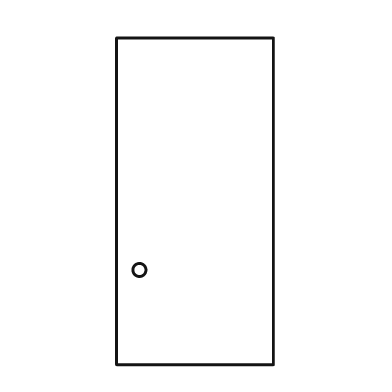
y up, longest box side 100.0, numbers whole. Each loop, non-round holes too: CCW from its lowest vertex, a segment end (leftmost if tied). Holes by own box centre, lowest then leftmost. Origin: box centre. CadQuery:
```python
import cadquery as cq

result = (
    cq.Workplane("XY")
    .moveTo(-24.0, -50.0)
    .lineTo(24.0, -50.0)
    .lineTo(24.0, 50.0)
    .lineTo(-24.0, 50.0)
    .close()
    .moveTo(-17.0, -21.0)
    .circle(2.0)
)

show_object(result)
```